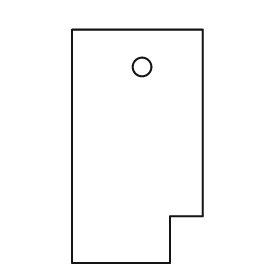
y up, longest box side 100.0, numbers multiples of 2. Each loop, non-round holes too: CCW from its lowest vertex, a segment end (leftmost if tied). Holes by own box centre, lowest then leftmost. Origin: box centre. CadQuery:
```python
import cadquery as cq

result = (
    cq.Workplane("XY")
    .moveTo(-28.0, -50.0)
    .lineTo(14.0, -50.0)
    .lineTo(14.0, -30.0)
    .lineTo(28.0, -30.0)
    .lineTo(28.0, 50.0)
    .lineTo(-28.0, 50.0)
    .close()
    .moveTo(2.0, 34.0)
    .circle(4.0)
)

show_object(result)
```